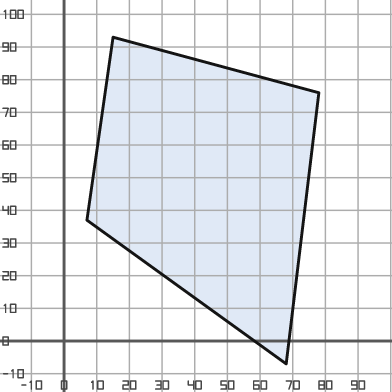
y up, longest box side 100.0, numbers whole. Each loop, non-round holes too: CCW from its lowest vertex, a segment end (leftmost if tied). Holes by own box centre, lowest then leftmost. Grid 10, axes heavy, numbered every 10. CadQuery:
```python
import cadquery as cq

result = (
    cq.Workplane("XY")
    .moveTo(68.0, -7.0)
    .lineTo(78.0, 76.0)
    .lineTo(15.0, 93.0)
    .lineTo(7.0, 37.0)
    .close()
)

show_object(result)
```